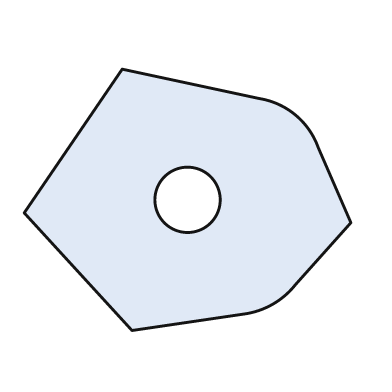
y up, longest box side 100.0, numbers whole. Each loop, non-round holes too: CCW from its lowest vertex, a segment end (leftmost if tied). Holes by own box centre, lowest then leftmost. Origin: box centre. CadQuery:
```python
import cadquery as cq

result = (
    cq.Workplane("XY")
    .moveTo(-17.0, -40.0)
    .lineTo(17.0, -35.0)
    .threePointArc((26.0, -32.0), (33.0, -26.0))
    .lineTo(50.0, -7.0)
    .lineTo(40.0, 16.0)
    .threePointArc((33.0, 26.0), (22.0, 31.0))
    .lineTo(-20.0, 40.0)
    .lineTo(-50.0, -4.0)
    .close()
    .moveTo(0.0, 0.0)
    .circle(10.0)
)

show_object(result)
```